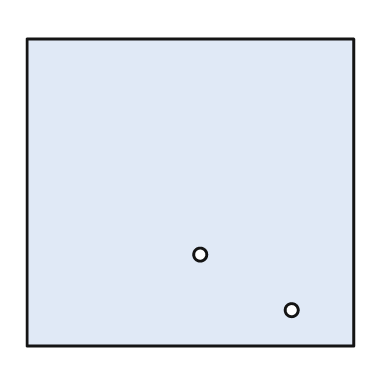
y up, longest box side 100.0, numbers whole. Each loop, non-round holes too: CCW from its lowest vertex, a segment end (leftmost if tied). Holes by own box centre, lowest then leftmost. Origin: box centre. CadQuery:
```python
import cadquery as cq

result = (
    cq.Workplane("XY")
    .moveTo(-50.0, -47.0)
    .lineTo(50.0, -47.0)
    .lineTo(50.0, 47.0)
    .lineTo(-50.0, 47.0)
    .close()
    .moveTo(31.0, -36.0)
    .circle(2.0)
    .moveTo(3.0, -19.0)
    .circle(2.0)
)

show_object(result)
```